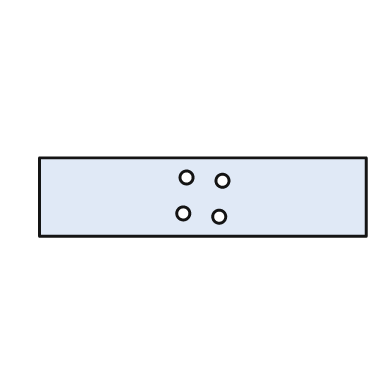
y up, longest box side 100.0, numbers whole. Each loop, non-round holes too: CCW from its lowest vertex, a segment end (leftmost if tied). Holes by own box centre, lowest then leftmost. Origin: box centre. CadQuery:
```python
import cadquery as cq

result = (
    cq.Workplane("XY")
    .moveTo(-50.0, -12.0)
    .lineTo(50.0, -12.0)
    .lineTo(50.0, 12.0)
    .lineTo(-50.0, 12.0)
    .close()
    .moveTo(5.0, -6.0)
    .circle(2.0)
    .moveTo(-6.0, -5.0)
    .circle(2.0)
    .moveTo(6.0, 5.0)
    .circle(2.0)
    .moveTo(-5.0, 6.0)
    .circle(2.0)
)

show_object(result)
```